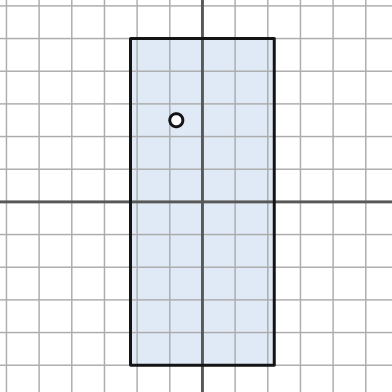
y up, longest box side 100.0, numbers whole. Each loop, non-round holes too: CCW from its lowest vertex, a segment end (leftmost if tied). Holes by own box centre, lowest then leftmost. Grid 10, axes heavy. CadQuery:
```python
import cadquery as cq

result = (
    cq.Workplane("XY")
    .moveTo(-22.0, -50.0)
    .lineTo(22.0, -50.0)
    .lineTo(22.0, 50.0)
    .lineTo(-22.0, 50.0)
    .close()
    .moveTo(-8.0, 25.0)
    .circle(2.0)
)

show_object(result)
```